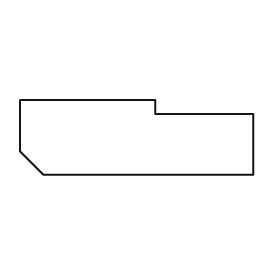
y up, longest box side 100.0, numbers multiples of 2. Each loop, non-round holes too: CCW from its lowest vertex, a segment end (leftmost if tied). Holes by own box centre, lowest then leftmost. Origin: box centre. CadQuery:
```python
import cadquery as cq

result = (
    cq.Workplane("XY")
    .moveTo(-40.0, -16.0)
    .lineTo(50.0, -16.0)
    .lineTo(50.0, 10.0)
    .lineTo(8.0, 10.0)
    .lineTo(8.0, 16.0)
    .lineTo(-50.0, 16.0)
    .lineTo(-50.0, -6.0)
    .close()
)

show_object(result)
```